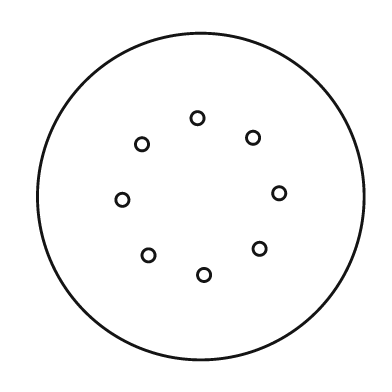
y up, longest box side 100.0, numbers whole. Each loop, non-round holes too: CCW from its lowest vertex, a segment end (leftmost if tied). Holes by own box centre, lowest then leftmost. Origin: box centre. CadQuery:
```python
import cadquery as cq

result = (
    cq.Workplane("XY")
    .moveTo(0.0, 0.0)
    .circle(50.0)
    .moveTo(1.0, -24.0)
    .circle(2.0)
    .moveTo(-16.0, -18.0)
    .circle(2.0)
    .moveTo(18.0, -16.0)
    .circle(2.0)
    .moveTo(-24.0, -1.0)
    .circle(2.0)
    .moveTo(24.0, 1.0)
    .circle(2.0)
    .moveTo(-18.0, 16.0)
    .circle(2.0)
    .moveTo(16.0, 18.0)
    .circle(2.0)
    .moveTo(-1.0, 24.0)
    .circle(2.0)
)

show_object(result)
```